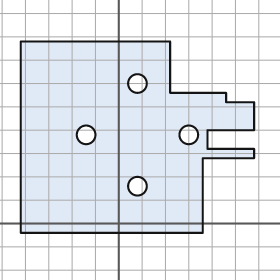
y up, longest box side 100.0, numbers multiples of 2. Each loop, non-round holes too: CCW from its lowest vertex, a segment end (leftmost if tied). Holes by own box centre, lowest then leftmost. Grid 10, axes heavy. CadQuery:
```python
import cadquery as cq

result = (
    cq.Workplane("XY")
    .moveTo(-42.0, -4.0)
    .lineTo(36.0, -4.0)
    .lineTo(36.0, 28.0)
    .lineTo(58.0, 28.0)
    .lineTo(58.0, 32.0)
    .lineTo(38.0, 32.0)
    .lineTo(38.0, 40.0)
    .lineTo(58.0, 40.0)
    .lineTo(58.0, 52.0)
    .lineTo(46.0, 52.0)
    .lineTo(46.0, 56.0)
    .lineTo(22.0, 56.0)
    .lineTo(22.0, 78.0)
    .lineTo(-42.0, 78.0)
    .close()
    .moveTo(8.0, 16.0)
    .circle(4.0)
    .moveTo(-14.0, 38.0)
    .circle(4.0)
    .moveTo(30.0, 38.0)
    .circle(4.0)
    .moveTo(8.0, 60.0)
    .circle(4.0)
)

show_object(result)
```